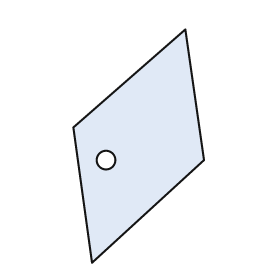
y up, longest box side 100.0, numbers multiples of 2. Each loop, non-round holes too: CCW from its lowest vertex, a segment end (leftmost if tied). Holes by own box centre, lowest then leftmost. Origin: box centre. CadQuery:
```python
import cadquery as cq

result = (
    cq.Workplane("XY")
    .moveTo(-20.0, -50.0)
    .lineTo(28.0, -6.0)
    .lineTo(20.0, 50.0)
    .lineTo(-28.0, 8.0)
    .close()
    .moveTo(-14.0, -6.0)
    .circle(4.0)
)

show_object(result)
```